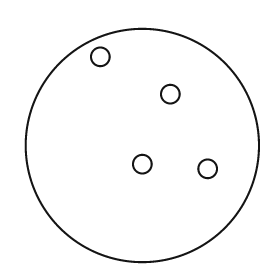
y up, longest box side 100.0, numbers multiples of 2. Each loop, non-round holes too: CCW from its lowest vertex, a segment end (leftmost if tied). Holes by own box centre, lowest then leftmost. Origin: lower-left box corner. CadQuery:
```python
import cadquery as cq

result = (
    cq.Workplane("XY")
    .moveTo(50.0, 50.0)
    .circle(50.0)
    .moveTo(78.0, 40.0)
    .circle(4.0)
    .moveTo(50.0, 42.0)
    .circle(4.0)
    .moveTo(62.0, 72.0)
    .circle(4.0)
    .moveTo(32.0, 88.0)
    .circle(4.0)
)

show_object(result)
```